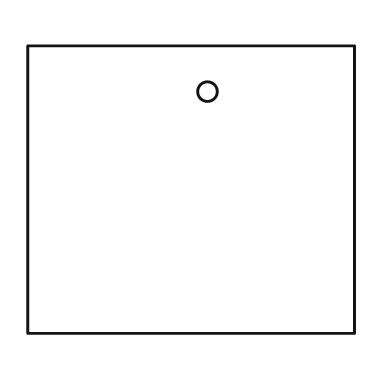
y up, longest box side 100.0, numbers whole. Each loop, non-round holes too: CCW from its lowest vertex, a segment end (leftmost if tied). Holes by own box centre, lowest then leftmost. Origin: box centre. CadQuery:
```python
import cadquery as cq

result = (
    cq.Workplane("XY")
    .moveTo(-50.0, -44.0)
    .lineTo(50.0, -44.0)
    .lineTo(50.0, 44.0)
    .lineTo(-50.0, 44.0)
    .close()
    .moveTo(5.0, 30.0)
    .circle(3.0)
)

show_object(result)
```